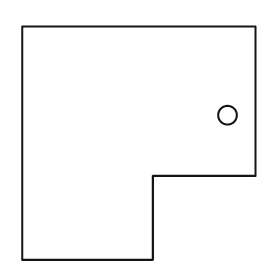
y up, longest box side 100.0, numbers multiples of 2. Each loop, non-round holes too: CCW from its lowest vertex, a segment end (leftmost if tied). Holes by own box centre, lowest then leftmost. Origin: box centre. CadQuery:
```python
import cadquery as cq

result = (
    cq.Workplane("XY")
    .moveTo(-50.0, -50.0)
    .lineTo(6.0, -50.0)
    .lineTo(6.0, -14.0)
    .lineTo(50.0, -14.0)
    .lineTo(50.0, 50.0)
    .lineTo(-50.0, 50.0)
    .close()
    .moveTo(38.0, 12.0)
    .circle(4.0)
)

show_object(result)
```